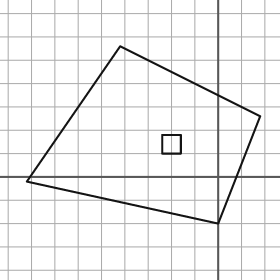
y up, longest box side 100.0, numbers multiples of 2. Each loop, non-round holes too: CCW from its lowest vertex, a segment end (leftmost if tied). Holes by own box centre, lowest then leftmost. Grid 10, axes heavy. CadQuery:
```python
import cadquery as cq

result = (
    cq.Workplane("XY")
    .moveTo(0.0, -20.0)
    .lineTo(18.0, 26.0)
    .lineTo(-42.0, 56.0)
    .lineTo(-82.0, -2.0)
    .close()
    .moveTo(-24.0, 10.0)
    .lineTo(-16.0, 10.0)
    .lineTo(-16.0, 18.0)
    .lineTo(-24.0, 18.0)
    .close()
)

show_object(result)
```